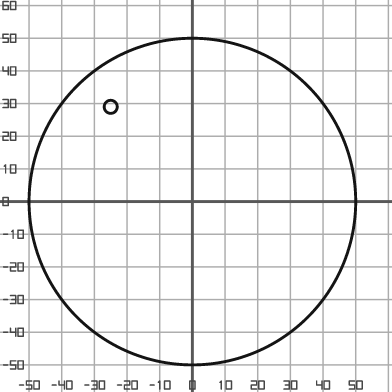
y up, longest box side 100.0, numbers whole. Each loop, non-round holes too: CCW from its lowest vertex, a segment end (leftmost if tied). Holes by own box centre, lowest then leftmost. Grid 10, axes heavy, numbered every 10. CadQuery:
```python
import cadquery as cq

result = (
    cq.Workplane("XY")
    .moveTo(0.0, 0.0)
    .circle(50.0)
    .moveTo(-25.0, 29.0)
    .circle(2.0)
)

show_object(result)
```